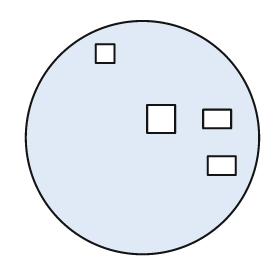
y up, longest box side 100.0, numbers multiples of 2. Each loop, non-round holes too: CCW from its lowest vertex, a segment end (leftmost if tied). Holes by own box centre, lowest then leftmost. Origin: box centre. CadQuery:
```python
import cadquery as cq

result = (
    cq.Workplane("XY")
    .moveTo(0.0, 0.0)
    .circle(50.0)
    .moveTo(28.0, -16.0)
    .lineTo(40.0, -16.0)
    .lineTo(40.0, -8.0)
    .lineTo(28.0, -8.0)
    .close()
    .moveTo(2.0, 2.0)
    .lineTo(14.0, 2.0)
    .lineTo(14.0, 14.0)
    .lineTo(2.0, 14.0)
    .close()
    .moveTo(26.0, 4.0)
    .lineTo(38.0, 4.0)
    .lineTo(38.0, 12.0)
    .lineTo(26.0, 12.0)
    .close()
    .moveTo(-20.0, 32.0)
    .lineTo(-12.0, 32.0)
    .lineTo(-12.0, 40.0)
    .lineTo(-20.0, 40.0)
    .close()
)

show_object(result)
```